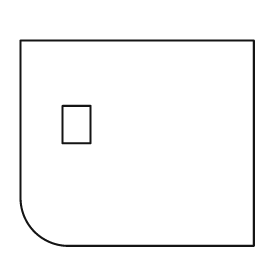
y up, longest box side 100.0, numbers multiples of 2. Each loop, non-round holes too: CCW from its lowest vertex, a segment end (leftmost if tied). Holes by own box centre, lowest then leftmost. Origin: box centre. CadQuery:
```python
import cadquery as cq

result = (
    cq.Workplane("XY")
    .moveTo(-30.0, -44.0)
    .lineTo(50.0, -44.0)
    .lineTo(50.0, 44.0)
    .lineTo(-50.0, 44.0)
    .lineTo(-50.0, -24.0)
    .threePointArc((-44.0, -38.0), (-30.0, -44.0))
    .close()
    .moveTo(-32.0, 0.0)
    .lineTo(-20.0, 0.0)
    .lineTo(-20.0, 16.0)
    .lineTo(-32.0, 16.0)
    .close()
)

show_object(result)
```